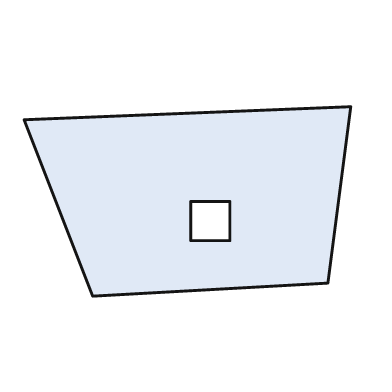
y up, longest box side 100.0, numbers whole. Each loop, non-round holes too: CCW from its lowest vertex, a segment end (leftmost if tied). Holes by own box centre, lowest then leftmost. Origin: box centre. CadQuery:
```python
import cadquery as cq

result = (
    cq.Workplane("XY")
    .moveTo(-29.0, -29.0)
    .lineTo(43.0, -25.0)
    .lineTo(50.0, 29.0)
    .lineTo(-50.0, 25.0)
    .close()
    .moveTo(1.0, -12.0)
    .lineTo(13.0, -12.0)
    .lineTo(13.0, 0.0)
    .lineTo(1.0, 0.0)
    .close()
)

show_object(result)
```